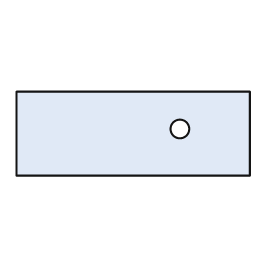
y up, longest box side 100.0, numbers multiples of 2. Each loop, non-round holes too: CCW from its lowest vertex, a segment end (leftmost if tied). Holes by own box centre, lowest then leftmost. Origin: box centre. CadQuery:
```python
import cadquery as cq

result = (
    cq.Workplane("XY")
    .moveTo(-50.0, -18.0)
    .lineTo(50.0, -18.0)
    .lineTo(50.0, 18.0)
    .lineTo(-50.0, 18.0)
    .close()
    .moveTo(20.0, 2.0)
    .circle(4.0)
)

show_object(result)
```